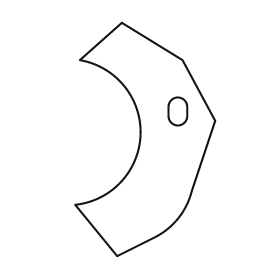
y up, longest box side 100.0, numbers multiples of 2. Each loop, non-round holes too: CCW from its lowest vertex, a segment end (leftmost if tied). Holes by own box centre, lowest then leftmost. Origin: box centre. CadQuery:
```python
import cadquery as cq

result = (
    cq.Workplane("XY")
    .moveTo(-12.0, -50.0)
    .lineTo(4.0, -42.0)
    .threePointArc((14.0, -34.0), (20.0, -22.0))
    .lineTo(30.0, 8.0)
    .lineTo(16.0, 34.0)
    .lineTo(-10.0, 50.0)
    .lineTo(-28.0, 34.0)
    .threePointArc((-2.0, 2.0), (-30.0, -28.0))
    .close()
    .moveTo(10.0, 10.0)
    .threePointArc((14.0, 6.0), (18.0, 10.0))
    .lineTo(18.0, 14.0)
    .threePointArc((14.0, 18.0), (10.0, 14.0))
    .close()
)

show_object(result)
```